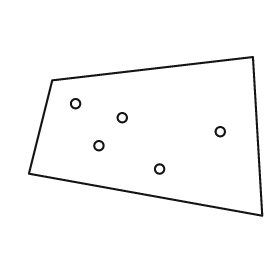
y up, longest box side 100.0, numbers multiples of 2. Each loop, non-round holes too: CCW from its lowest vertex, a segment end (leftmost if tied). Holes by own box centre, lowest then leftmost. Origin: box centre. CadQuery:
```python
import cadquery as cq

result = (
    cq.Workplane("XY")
    .moveTo(50.0, -34.0)
    .lineTo(46.0, 34.0)
    .lineTo(-40.0, 24.0)
    .lineTo(-50.0, -16.0)
    .close()
    .moveTo(6.0, -14.0)
    .circle(2.0)
    .moveTo(-20.0, -4.0)
    .circle(2.0)
    .moveTo(32.0, 2.0)
    .circle(2.0)
    .moveTo(-10.0, 8.0)
    .circle(2.0)
    .moveTo(-30.0, 14.0)
    .circle(2.0)
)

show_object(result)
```